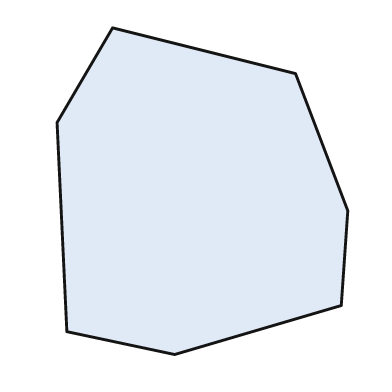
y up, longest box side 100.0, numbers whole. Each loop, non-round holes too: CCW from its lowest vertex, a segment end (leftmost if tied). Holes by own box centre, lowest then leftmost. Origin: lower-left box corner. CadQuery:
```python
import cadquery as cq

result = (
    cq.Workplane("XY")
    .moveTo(36.0, 0.0)
    .lineTo(87.0, 15.0)
    .lineTo(89.0, 44.0)
    .lineTo(73.0, 86.0)
    .lineTo(17.0, 100.0)
    .lineTo(0.0, 71.0)
    .lineTo(3.0, 7.0)
    .close()
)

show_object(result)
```